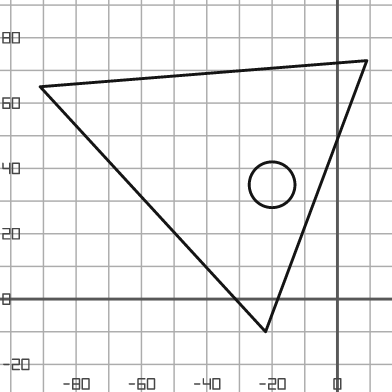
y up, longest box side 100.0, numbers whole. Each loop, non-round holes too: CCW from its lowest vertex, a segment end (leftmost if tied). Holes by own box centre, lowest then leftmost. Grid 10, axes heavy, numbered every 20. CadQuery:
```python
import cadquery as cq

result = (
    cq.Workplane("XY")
    .moveTo(-22.0, -10.0)
    .lineTo(9.0, 73.0)
    .lineTo(-91.0, 65.0)
    .close()
    .moveTo(-20.0, 35.0)
    .circle(7.0)
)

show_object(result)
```